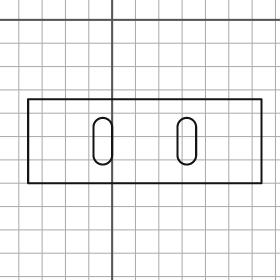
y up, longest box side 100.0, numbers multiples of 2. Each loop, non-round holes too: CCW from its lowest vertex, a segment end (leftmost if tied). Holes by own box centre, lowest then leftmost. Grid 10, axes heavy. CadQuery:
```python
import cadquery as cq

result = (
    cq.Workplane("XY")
    .moveTo(-36.0, -70.0)
    .lineTo(64.0, -70.0)
    .lineTo(64.0, -34.0)
    .lineTo(-36.0, -34.0)
    .close()
    .moveTo(-8.0, -58.0)
    .threePointArc((-4.0, -62.0), (0.0, -58.0))
    .lineTo(0.0, -46.0)
    .threePointArc((-4.0, -42.0), (-8.0, -46.0))
    .close()
    .moveTo(28.0, -58.0)
    .threePointArc((32.0, -62.0), (36.0, -58.0))
    .lineTo(36.0, -46.0)
    .threePointArc((32.0, -42.0), (28.0, -46.0))
    .close()
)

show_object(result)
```